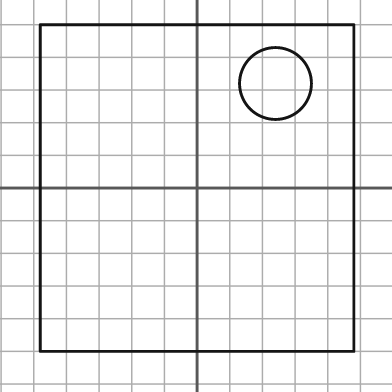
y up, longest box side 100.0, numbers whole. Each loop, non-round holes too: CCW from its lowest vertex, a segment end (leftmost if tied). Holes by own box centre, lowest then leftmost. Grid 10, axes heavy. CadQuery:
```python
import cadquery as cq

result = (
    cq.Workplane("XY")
    .moveTo(-48.0, -50.0)
    .lineTo(48.0, -50.0)
    .lineTo(48.0, 50.0)
    .lineTo(-48.0, 50.0)
    .close()
    .moveTo(24.0, 32.0)
    .circle(11.0)
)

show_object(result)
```